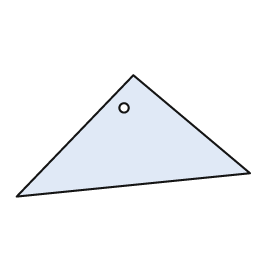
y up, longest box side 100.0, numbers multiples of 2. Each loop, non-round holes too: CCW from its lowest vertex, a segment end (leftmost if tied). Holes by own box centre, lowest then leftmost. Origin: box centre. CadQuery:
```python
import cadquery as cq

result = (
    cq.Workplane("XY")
    .moveTo(-50.0, -26.0)
    .lineTo(50.0, -16.0)
    .lineTo(0.0, 26.0)
    .close()
    .moveTo(-4.0, 12.0)
    .circle(2.0)
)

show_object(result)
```